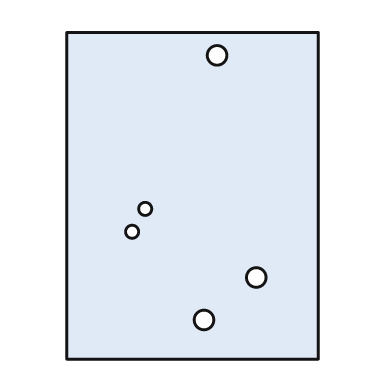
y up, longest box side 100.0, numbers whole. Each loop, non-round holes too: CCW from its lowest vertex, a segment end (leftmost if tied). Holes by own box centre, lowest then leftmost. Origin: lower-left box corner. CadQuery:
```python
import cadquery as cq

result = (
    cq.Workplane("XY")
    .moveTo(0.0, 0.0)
    .lineTo(77.0, 0.0)
    .lineTo(77.0, 100.0)
    .lineTo(0.0, 100.0)
    .close()
    .moveTo(42.0, 12.0)
    .circle(3.0)
    .moveTo(58.0, 25.0)
    .circle(3.0)
    .moveTo(20.0, 39.0)
    .circle(2.0)
    .moveTo(24.0, 46.0)
    .circle(2.0)
    .moveTo(46.0, 93.0)
    .circle(3.0)
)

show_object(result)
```